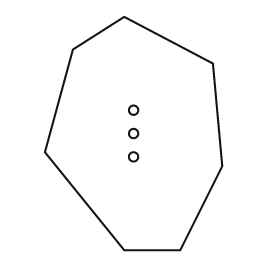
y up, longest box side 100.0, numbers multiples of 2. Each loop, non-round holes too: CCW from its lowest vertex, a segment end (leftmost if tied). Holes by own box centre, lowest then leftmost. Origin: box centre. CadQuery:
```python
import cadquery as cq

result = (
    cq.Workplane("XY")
    .moveTo(-4.0, -50.0)
    .lineTo(20.0, -50.0)
    .lineTo(38.0, -14.0)
    .lineTo(34.0, 30.0)
    .lineTo(-4.0, 50.0)
    .lineTo(-26.0, 36.0)
    .lineTo(-38.0, -8.0)
    .close()
    .moveTo(0.0, -10.0)
    .circle(2.0)
    .moveTo(0.0, 0.0)
    .circle(2.0)
    .moveTo(0.0, 10.0)
    .circle(2.0)
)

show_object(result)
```